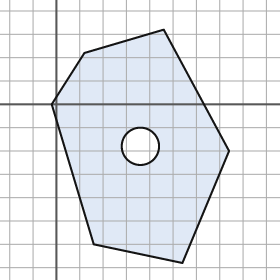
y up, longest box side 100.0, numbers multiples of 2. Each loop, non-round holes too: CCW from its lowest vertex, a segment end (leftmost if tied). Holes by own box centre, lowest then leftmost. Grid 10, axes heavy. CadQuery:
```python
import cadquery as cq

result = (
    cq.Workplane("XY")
    .moveTo(54.0, -68.0)
    .lineTo(74.0, -20.0)
    .lineTo(46.0, 32.0)
    .lineTo(12.0, 22.0)
    .lineTo(-2.0, 0.0)
    .lineTo(16.0, -60.0)
    .close()
    .moveTo(36.0, -18.0)
    .circle(8.0)
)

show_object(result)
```